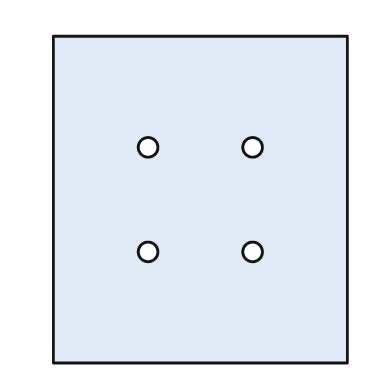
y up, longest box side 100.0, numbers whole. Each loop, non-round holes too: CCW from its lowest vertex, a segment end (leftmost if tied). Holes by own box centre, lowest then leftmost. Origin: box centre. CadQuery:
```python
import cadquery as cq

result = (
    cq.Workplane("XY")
    .moveTo(-45.0, -50.0)
    .lineTo(45.0, -50.0)
    .lineTo(45.0, 50.0)
    .lineTo(-45.0, 50.0)
    .close()
    .moveTo(-16.0, -16.0)
    .circle(3.0)
    .moveTo(16.0, -16.0)
    .circle(3.0)
    .moveTo(-16.0, 16.0)
    .circle(3.0)
    .moveTo(16.0, 16.0)
    .circle(3.0)
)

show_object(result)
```